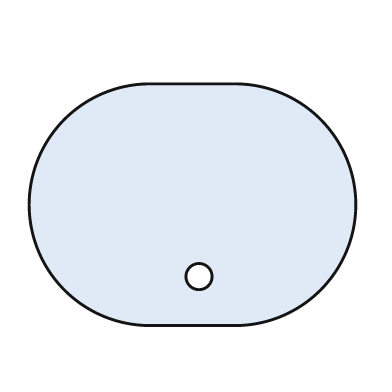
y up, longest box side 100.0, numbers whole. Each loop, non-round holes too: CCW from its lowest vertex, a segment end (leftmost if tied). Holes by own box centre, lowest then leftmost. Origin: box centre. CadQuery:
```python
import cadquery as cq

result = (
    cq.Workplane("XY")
    .moveTo(-13.0, -37.0)
    .lineTo(13.0, -37.0)
    .threePointArc((50.0, 0.0), (13.0, 37.0))
    .lineTo(-13.0, 37.0)
    .threePointArc((-50.0, 0.0), (-13.0, -37.0))
    .close()
    .moveTo(2.0, -22.0)
    .circle(4.0)
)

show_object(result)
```